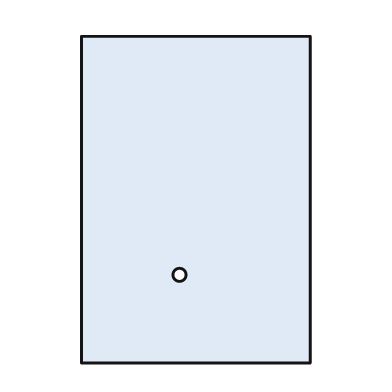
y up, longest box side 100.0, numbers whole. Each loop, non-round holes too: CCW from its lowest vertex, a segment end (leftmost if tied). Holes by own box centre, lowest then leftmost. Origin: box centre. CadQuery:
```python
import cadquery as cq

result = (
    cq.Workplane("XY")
    .moveTo(-35.0, -50.0)
    .lineTo(35.0, -50.0)
    .lineTo(35.0, 50.0)
    .lineTo(-35.0, 50.0)
    .close()
    .moveTo(-5.0, -23.0)
    .circle(2.0)
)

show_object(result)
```